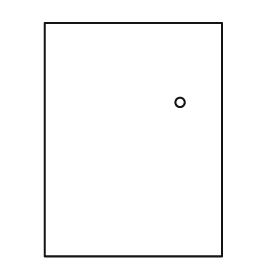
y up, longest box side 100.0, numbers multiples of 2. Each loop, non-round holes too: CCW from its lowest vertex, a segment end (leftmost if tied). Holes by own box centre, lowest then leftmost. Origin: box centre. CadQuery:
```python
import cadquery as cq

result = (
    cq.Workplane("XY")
    .moveTo(-38.0, -50.0)
    .lineTo(38.0, -50.0)
    .lineTo(38.0, 50.0)
    .lineTo(-38.0, 50.0)
    .close()
    .moveTo(20.0, 16.0)
    .circle(2.0)
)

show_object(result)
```